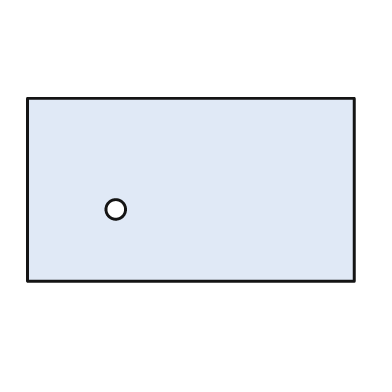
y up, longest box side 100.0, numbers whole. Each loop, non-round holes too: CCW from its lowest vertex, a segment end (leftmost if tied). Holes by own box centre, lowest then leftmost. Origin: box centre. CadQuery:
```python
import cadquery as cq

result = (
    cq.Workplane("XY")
    .moveTo(-50.0, -28.0)
    .lineTo(50.0, -28.0)
    .lineTo(50.0, 28.0)
    .lineTo(-50.0, 28.0)
    .close()
    .moveTo(-23.0, -6.0)
    .circle(3.0)
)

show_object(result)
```